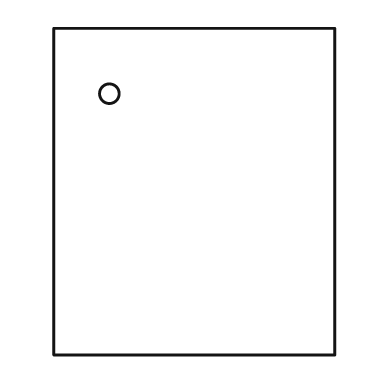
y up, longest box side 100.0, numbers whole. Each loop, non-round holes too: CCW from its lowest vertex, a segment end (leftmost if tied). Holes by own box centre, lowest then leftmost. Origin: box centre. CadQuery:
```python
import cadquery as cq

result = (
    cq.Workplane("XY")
    .moveTo(-43.0, -50.0)
    .lineTo(43.0, -50.0)
    .lineTo(43.0, 50.0)
    .lineTo(-43.0, 50.0)
    .close()
    .moveTo(-26.0, 30.0)
    .circle(3.0)
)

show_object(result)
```